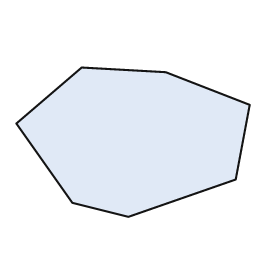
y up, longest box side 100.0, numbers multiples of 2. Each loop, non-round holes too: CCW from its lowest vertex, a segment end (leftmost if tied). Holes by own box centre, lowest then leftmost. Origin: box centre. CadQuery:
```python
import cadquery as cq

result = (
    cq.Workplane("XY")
    .moveTo(-2.0, -32.0)
    .lineTo(44.0, -16.0)
    .lineTo(50.0, 16.0)
    .lineTo(14.0, 30.0)
    .lineTo(-22.0, 32.0)
    .lineTo(-50.0, 8.0)
    .lineTo(-26.0, -26.0)
    .close()
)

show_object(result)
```